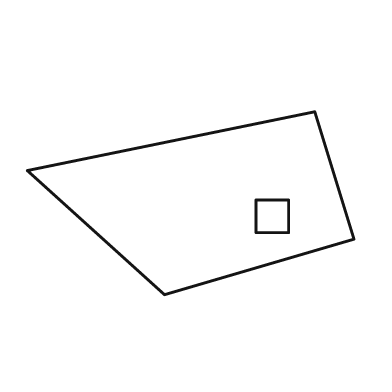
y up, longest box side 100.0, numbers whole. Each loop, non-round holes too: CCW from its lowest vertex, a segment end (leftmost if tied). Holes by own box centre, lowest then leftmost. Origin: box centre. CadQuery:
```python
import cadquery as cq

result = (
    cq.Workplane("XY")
    .moveTo(-8.0, -28.0)
    .lineTo(50.0, -11.0)
    .lineTo(38.0, 28.0)
    .lineTo(-50.0, 10.0)
    .close()
    .moveTo(20.0, -9.0)
    .lineTo(30.0, -9.0)
    .lineTo(30.0, 1.0)
    .lineTo(20.0, 1.0)
    .close()
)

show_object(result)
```